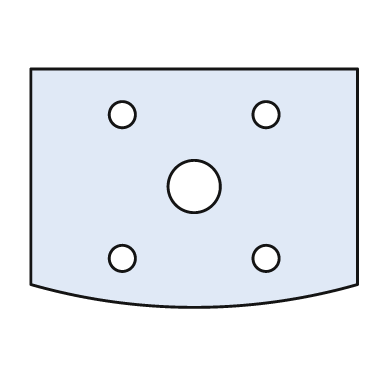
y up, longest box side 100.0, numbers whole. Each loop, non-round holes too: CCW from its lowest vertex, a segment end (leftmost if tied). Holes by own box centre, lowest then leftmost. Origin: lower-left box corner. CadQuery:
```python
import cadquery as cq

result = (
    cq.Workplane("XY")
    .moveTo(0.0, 7.0)
    .threePointArc((50.0, 0.0), (100.0, 7.0))
    .lineTo(100.0, 73.0)
    .lineTo(0.0, 73.0)
    .close()
    .moveTo(28.0, 15.0)
    .circle(4.0)
    .moveTo(72.0, 15.0)
    .circle(4.0)
    .moveTo(50.0, 37.0)
    .circle(8.0)
    .moveTo(28.0, 59.0)
    .circle(4.0)
    .moveTo(72.0, 59.0)
    .circle(4.0)
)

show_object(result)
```